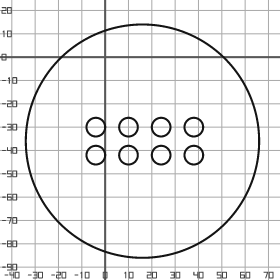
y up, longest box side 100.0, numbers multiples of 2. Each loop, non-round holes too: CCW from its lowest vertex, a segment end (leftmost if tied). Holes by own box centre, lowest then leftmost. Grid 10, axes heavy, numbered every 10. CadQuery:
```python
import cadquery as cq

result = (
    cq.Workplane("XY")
    .moveTo(16.0, -36.0)
    .circle(50.0)
    .moveTo(-4.0, -42.0)
    .circle(4.0)
    .moveTo(10.0, -42.0)
    .circle(4.0)
    .moveTo(24.0, -42.0)
    .circle(4.0)
    .moveTo(38.0, -42.0)
    .circle(4.0)
    .moveTo(-4.0, -30.0)
    .circle(4.0)
    .moveTo(10.0, -30.0)
    .circle(4.0)
    .moveTo(24.0, -30.0)
    .circle(4.0)
    .moveTo(38.0, -30.0)
    .circle(4.0)
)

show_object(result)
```